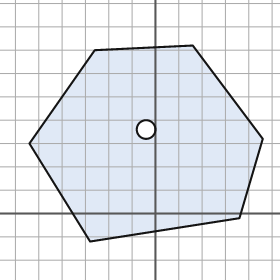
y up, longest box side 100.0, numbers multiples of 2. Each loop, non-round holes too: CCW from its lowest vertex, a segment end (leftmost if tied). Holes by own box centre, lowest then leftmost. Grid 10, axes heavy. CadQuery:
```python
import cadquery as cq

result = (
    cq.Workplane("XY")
    .moveTo(-28.0, -12.0)
    .lineTo(36.0, -2.0)
    .lineTo(46.0, 32.0)
    .lineTo(16.0, 72.0)
    .lineTo(-26.0, 70.0)
    .lineTo(-54.0, 30.0)
    .close()
    .moveTo(-4.0, 36.0)
    .circle(4.0)
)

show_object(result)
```